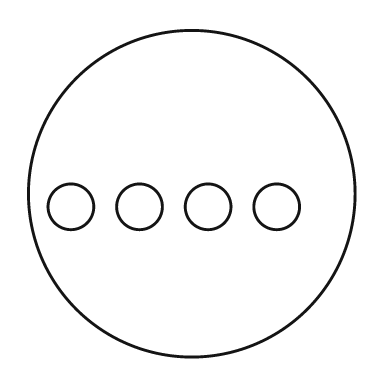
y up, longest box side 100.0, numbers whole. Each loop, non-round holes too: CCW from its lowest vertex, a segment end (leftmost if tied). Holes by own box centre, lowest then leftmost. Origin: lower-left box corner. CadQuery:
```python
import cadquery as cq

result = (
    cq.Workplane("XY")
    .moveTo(50.0, 50.0)
    .circle(50.0)
    .moveTo(13.0, 46.0)
    .circle(7.0)
    .moveTo(34.0, 46.0)
    .circle(7.0)
    .moveTo(55.0, 46.0)
    .circle(7.0)
    .moveTo(76.0, 46.0)
    .circle(7.0)
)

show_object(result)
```